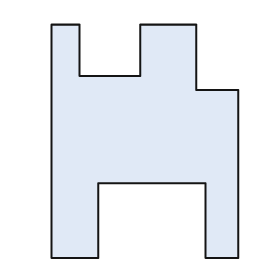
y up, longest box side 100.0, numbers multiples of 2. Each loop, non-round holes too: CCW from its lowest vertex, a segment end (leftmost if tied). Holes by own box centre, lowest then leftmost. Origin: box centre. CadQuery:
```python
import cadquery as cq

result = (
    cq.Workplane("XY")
    .moveTo(-40.0, -50.0)
    .lineTo(-20.0, -50.0)
    .lineTo(-20.0, -18.0)
    .lineTo(26.0, -18.0)
    .lineTo(26.0, -50.0)
    .lineTo(40.0, -50.0)
    .lineTo(40.0, 22.0)
    .lineTo(22.0, 22.0)
    .lineTo(22.0, 50.0)
    .lineTo(-2.0, 50.0)
    .lineTo(-2.0, 28.0)
    .lineTo(-28.0, 28.0)
    .lineTo(-28.0, 50.0)
    .lineTo(-40.0, 50.0)
    .close()
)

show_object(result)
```